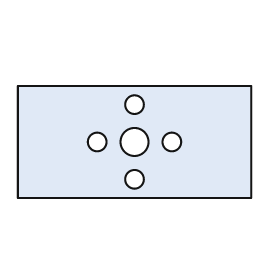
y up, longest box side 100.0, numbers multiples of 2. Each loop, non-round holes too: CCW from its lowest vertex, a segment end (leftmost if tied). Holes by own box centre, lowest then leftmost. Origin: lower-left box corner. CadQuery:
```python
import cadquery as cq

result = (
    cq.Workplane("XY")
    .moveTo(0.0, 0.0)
    .lineTo(100.0, 0.0)
    .lineTo(100.0, 48.0)
    .lineTo(0.0, 48.0)
    .close()
    .moveTo(50.0, 8.0)
    .circle(4.0)
    .moveTo(34.0, 24.0)
    .circle(4.0)
    .moveTo(50.0, 24.0)
    .circle(6.0)
    .moveTo(66.0, 24.0)
    .circle(4.0)
    .moveTo(50.0, 40.0)
    .circle(4.0)
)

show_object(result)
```